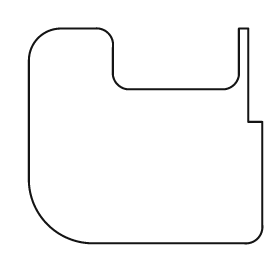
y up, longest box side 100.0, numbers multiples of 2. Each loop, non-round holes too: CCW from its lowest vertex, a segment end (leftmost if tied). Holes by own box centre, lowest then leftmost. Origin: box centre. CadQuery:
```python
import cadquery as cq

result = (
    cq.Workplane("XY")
    .moveTo(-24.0, -46.0)
    .lineTo(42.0, -46.0)
    .threePointArc((48.0, -44.0), (50.0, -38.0))
    .lineTo(50.0, 6.0)
    .lineTo(44.0, 6.0)
    .lineTo(44.0, 46.0)
    .lineTo(40.0, 46.0)
    .lineTo(40.0, 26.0)
    .threePointArc((38.0, 22.0), (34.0, 20.0))
    .lineTo(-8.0, 20.0)
    .threePointArc((-12.0, 22.0), (-14.0, 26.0))
    .lineTo(-14.0, 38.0)
    .threePointArc((-16.0, 44.0), (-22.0, 46.0))
    .lineTo(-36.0, 46.0)
    .threePointArc((-46.0, 42.0), (-50.0, 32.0))
    .lineTo(-50.0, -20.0)
    .threePointArc((-42.0, -38.0), (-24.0, -46.0))
    .close()
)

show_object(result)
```